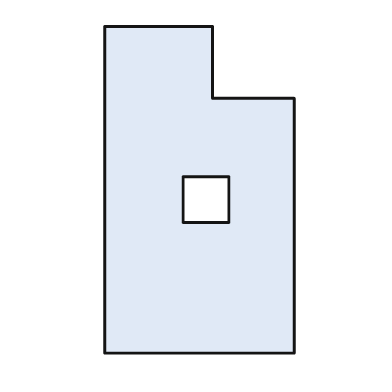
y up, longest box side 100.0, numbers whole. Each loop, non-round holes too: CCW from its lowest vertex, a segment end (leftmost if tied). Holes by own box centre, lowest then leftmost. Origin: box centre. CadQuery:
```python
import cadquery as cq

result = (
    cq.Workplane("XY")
    .moveTo(-29.0, -50.0)
    .lineTo(29.0, -50.0)
    .lineTo(29.0, 28.0)
    .lineTo(4.0, 28.0)
    .lineTo(4.0, 50.0)
    .lineTo(-29.0, 50.0)
    .close()
    .moveTo(-5.0, -10.0)
    .lineTo(9.0, -10.0)
    .lineTo(9.0, 4.0)
    .lineTo(-5.0, 4.0)
    .close()
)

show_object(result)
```